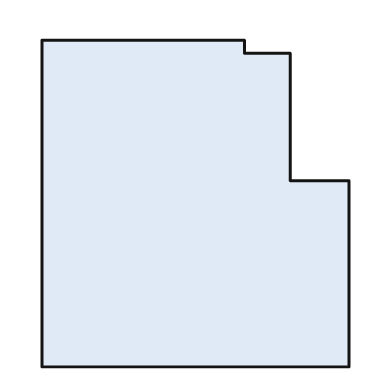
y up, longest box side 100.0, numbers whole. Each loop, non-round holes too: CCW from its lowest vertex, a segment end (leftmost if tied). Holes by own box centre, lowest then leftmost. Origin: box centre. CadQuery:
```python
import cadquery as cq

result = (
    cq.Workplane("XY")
    .moveTo(-47.0, -50.0)
    .lineTo(47.0, -50.0)
    .lineTo(47.0, 7.0)
    .lineTo(29.0, 7.0)
    .lineTo(29.0, 46.0)
    .lineTo(15.0, 46.0)
    .lineTo(15.0, 50.0)
    .lineTo(-47.0, 50.0)
    .close()
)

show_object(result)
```